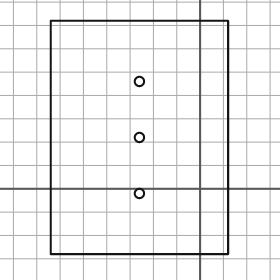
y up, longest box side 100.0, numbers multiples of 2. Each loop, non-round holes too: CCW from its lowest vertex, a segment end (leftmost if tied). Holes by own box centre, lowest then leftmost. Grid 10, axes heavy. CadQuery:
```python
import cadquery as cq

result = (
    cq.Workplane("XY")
    .moveTo(-64.0, -28.0)
    .lineTo(12.0, -28.0)
    .lineTo(12.0, 72.0)
    .lineTo(-64.0, 72.0)
    .close()
    .moveTo(-26.0, -2.0)
    .circle(2.0)
    .moveTo(-26.0, 22.0)
    .circle(2.0)
    .moveTo(-26.0, 46.0)
    .circle(2.0)
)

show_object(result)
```